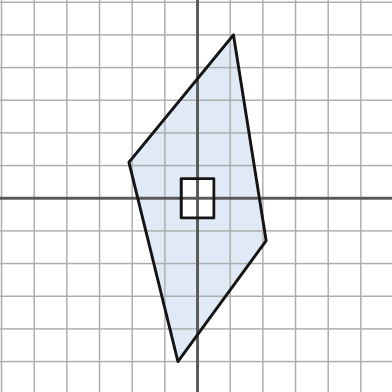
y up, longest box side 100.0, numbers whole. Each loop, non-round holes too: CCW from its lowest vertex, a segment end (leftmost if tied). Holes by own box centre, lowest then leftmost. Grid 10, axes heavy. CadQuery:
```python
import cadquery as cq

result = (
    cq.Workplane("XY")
    .moveTo(-6.0, -50.0)
    .lineTo(21.0, -13.0)
    .lineTo(11.0, 50.0)
    .lineTo(-21.0, 11.0)
    .close()
    .moveTo(-5.0, -6.0)
    .lineTo(5.0, -6.0)
    .lineTo(5.0, 6.0)
    .lineTo(-5.0, 6.0)
    .close()
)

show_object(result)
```